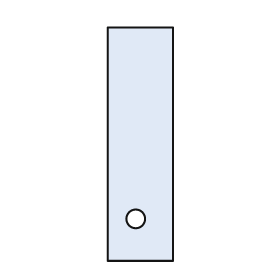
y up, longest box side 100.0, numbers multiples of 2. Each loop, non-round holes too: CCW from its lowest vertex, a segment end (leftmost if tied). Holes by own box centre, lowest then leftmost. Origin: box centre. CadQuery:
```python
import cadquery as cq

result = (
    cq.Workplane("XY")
    .moveTo(-14.0, -50.0)
    .lineTo(14.0, -50.0)
    .lineTo(14.0, 50.0)
    .lineTo(-14.0, 50.0)
    .close()
    .moveTo(-2.0, -32.0)
    .circle(4.0)
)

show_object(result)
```